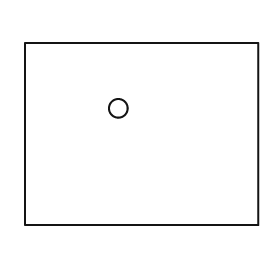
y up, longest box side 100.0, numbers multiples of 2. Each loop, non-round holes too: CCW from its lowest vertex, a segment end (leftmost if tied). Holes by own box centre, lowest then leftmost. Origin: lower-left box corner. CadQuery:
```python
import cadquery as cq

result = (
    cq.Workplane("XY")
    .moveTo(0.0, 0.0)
    .lineTo(100.0, 0.0)
    .lineTo(100.0, 78.0)
    .lineTo(0.0, 78.0)
    .close()
    .moveTo(40.0, 50.0)
    .circle(4.0)
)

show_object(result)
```